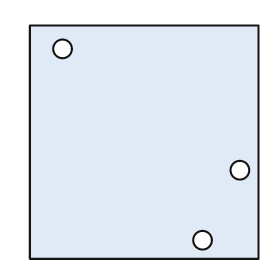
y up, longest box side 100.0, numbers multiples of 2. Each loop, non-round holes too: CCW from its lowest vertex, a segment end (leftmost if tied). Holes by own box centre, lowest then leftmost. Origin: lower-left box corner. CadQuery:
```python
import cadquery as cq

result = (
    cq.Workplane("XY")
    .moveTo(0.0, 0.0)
    .lineTo(98.0, 0.0)
    .lineTo(98.0, 100.0)
    .lineTo(0.0, 100.0)
    .close()
    .moveTo(74.0, 8.0)
    .circle(4.0)
    .moveTo(90.0, 38.0)
    .circle(4.0)
    .moveTo(14.0, 90.0)
    .circle(4.0)
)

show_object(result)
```